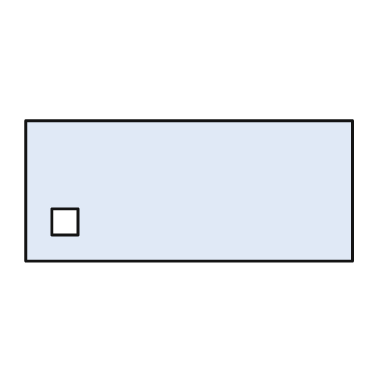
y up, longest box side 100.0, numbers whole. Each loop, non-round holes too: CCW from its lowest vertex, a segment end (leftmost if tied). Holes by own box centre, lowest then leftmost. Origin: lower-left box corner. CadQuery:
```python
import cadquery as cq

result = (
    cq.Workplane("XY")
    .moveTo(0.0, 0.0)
    .lineTo(100.0, 0.0)
    .lineTo(100.0, 43.0)
    .lineTo(0.0, 43.0)
    .close()
    .moveTo(8.0, 8.0)
    .lineTo(16.0, 8.0)
    .lineTo(16.0, 16.0)
    .lineTo(8.0, 16.0)
    .close()
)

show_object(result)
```